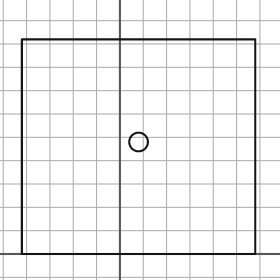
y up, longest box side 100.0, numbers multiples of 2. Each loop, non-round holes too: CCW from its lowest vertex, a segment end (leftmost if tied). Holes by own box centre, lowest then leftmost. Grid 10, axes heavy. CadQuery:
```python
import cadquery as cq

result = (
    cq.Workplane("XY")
    .moveTo(-42.0, 0.0)
    .lineTo(58.0, 0.0)
    .lineTo(58.0, 92.0)
    .lineTo(-42.0, 92.0)
    .close()
    .moveTo(8.0, 48.0)
    .circle(4.0)
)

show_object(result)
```